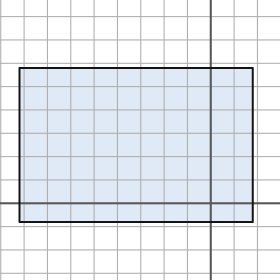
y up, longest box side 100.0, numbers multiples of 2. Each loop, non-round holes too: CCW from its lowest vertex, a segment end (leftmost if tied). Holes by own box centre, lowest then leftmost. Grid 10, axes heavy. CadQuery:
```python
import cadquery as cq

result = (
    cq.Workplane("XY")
    .moveTo(-82.0, -8.0)
    .lineTo(18.0, -8.0)
    .lineTo(18.0, 58.0)
    .lineTo(-82.0, 58.0)
    .close()
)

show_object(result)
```